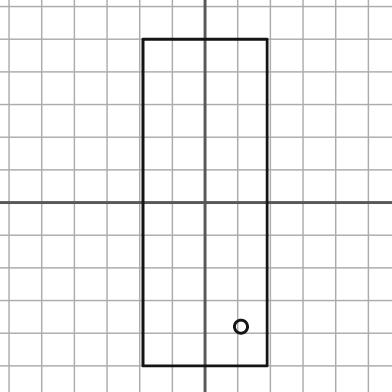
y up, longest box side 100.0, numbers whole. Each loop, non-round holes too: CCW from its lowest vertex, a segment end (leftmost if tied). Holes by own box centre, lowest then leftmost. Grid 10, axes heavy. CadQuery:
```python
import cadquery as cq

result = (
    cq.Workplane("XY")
    .moveTo(-19.0, -50.0)
    .lineTo(19.0, -50.0)
    .lineTo(19.0, 50.0)
    .lineTo(-19.0, 50.0)
    .close()
    .moveTo(11.0, -38.0)
    .circle(2.0)
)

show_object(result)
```